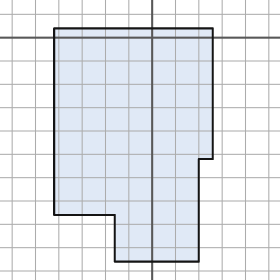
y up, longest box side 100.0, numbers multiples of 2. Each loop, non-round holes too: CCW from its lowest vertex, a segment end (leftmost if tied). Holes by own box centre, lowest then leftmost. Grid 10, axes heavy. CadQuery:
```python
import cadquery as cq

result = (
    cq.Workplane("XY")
    .moveTo(-16.0, -96.0)
    .lineTo(20.0, -96.0)
    .lineTo(20.0, -52.0)
    .lineTo(26.0, -52.0)
    .lineTo(26.0, 4.0)
    .lineTo(-42.0, 4.0)
    .lineTo(-42.0, -76.0)
    .lineTo(-16.0, -76.0)
    .close()
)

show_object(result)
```